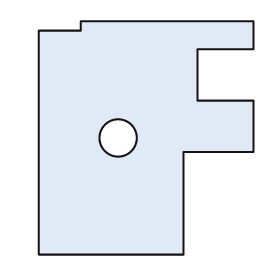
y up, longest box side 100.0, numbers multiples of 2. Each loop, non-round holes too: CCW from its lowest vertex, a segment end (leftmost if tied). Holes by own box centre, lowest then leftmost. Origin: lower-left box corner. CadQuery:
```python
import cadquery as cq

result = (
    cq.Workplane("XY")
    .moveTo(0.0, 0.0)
    .lineTo(62.0, 0.0)
    .lineTo(62.0, 44.0)
    .lineTo(92.0, 44.0)
    .lineTo(92.0, 66.0)
    .lineTo(68.0, 66.0)
    .lineTo(68.0, 88.0)
    .lineTo(92.0, 88.0)
    .lineTo(92.0, 100.0)
    .lineTo(18.0, 100.0)
    .lineTo(18.0, 96.0)
    .lineTo(0.0, 96.0)
    .close()
    .moveTo(34.0, 50.0)
    .circle(8.0)
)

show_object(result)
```